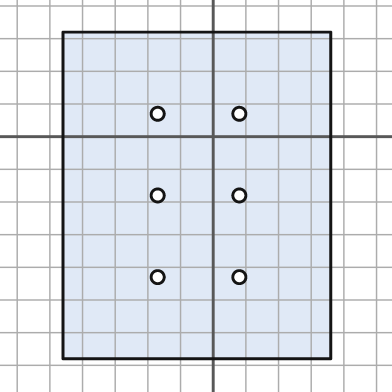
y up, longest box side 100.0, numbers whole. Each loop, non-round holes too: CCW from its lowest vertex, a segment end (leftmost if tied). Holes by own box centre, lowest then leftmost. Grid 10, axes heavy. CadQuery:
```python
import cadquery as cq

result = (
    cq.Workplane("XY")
    .moveTo(-46.0, -68.0)
    .lineTo(36.0, -68.0)
    .lineTo(36.0, 32.0)
    .lineTo(-46.0, 32.0)
    .close()
    .moveTo(-17.0, -43.0)
    .circle(2.0)
    .moveTo(8.0, -43.0)
    .circle(2.0)
    .moveTo(-17.0, -18.0)
    .circle(2.0)
    .moveTo(8.0, -18.0)
    .circle(2.0)
    .moveTo(-17.0, 7.0)
    .circle(2.0)
    .moveTo(8.0, 7.0)
    .circle(2.0)
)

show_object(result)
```